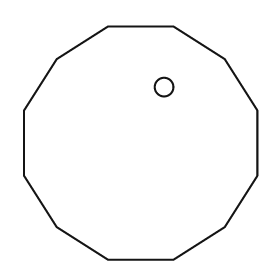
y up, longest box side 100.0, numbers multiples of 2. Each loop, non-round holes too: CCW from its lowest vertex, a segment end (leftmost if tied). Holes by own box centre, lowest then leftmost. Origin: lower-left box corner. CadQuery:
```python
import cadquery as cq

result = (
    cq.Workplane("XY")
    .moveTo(36.0, 0.0)
    .lineTo(64.0, 0.0)
    .lineTo(86.0, 14.0)
    .lineTo(100.0, 36.0)
    .lineTo(100.0, 64.0)
    .lineTo(86.0, 86.0)
    .lineTo(64.0, 100.0)
    .lineTo(36.0, 100.0)
    .lineTo(14.0, 86.0)
    .lineTo(0.0, 64.0)
    .lineTo(0.0, 36.0)
    .lineTo(14.0, 14.0)
    .close()
    .moveTo(60.0, 74.0)
    .circle(4.0)
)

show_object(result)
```